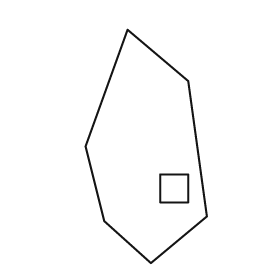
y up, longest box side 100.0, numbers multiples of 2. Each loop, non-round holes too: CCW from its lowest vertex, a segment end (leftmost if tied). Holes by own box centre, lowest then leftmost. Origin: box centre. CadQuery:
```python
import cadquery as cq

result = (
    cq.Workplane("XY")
    .moveTo(2.0, -50.0)
    .lineTo(26.0, -30.0)
    .lineTo(18.0, 28.0)
    .lineTo(-8.0, 50.0)
    .lineTo(-26.0, 0.0)
    .lineTo(-18.0, -32.0)
    .close()
    .moveTo(6.0, -24.0)
    .lineTo(18.0, -24.0)
    .lineTo(18.0, -12.0)
    .lineTo(6.0, -12.0)
    .close()
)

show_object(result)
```